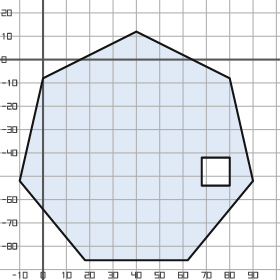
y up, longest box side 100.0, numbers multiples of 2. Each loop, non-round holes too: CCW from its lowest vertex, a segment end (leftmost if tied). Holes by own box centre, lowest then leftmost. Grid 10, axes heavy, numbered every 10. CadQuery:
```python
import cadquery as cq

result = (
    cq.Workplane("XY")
    .moveTo(18.0, -86.0)
    .lineTo(62.0, -86.0)
    .lineTo(90.0, -52.0)
    .lineTo(80.0, -8.0)
    .lineTo(40.0, 12.0)
    .lineTo(0.0, -8.0)
    .lineTo(-10.0, -52.0)
    .close()
    .moveTo(68.0, -54.0)
    .lineTo(80.0, -54.0)
    .lineTo(80.0, -42.0)
    .lineTo(68.0, -42.0)
    .close()
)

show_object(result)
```